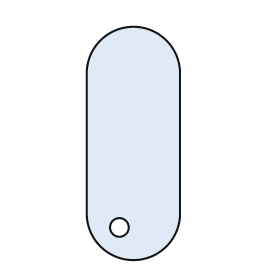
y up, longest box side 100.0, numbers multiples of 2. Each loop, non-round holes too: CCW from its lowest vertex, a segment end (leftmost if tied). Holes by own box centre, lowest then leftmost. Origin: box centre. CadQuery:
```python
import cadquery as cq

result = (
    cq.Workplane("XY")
    .moveTo(-20.0, -30.0)
    .threePointArc((0.0, -50.0), (20.0, -30.0))
    .lineTo(20.0, 30.0)
    .threePointArc((0.0, 50.0), (-20.0, 30.0))
    .close()
    .moveTo(-6.0, -36.0)
    .circle(4.0)
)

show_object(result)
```